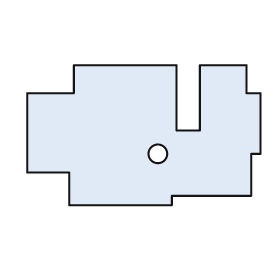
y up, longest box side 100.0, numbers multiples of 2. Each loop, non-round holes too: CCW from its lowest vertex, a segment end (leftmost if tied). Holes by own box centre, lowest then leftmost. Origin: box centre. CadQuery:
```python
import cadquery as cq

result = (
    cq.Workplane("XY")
    .moveTo(-32.0, -30.0)
    .lineTo(12.0, -30.0)
    .lineTo(12.0, -26.0)
    .lineTo(46.0, -26.0)
    .lineTo(46.0, -8.0)
    .lineTo(50.0, -8.0)
    .lineTo(50.0, 18.0)
    .lineTo(44.0, 18.0)
    .lineTo(44.0, 30.0)
    .lineTo(24.0, 30.0)
    .lineTo(24.0, 2.0)
    .lineTo(14.0, 2.0)
    .lineTo(14.0, 30.0)
    .lineTo(-30.0, 30.0)
    .lineTo(-30.0, 18.0)
    .lineTo(-50.0, 18.0)
    .lineTo(-50.0, -16.0)
    .lineTo(-32.0, -16.0)
    .close()
    .moveTo(6.0, -8.0)
    .circle(4.0)
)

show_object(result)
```